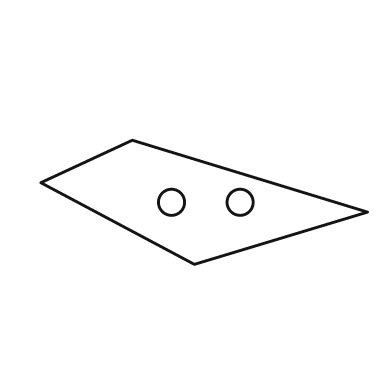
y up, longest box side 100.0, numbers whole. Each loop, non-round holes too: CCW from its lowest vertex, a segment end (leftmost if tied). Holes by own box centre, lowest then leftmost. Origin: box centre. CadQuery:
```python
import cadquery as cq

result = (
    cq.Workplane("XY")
    .moveTo(-3.0, -19.0)
    .lineTo(50.0, -3.0)
    .lineTo(-22.0, 19.0)
    .lineTo(-50.0, 6.0)
    .close()
    .moveTo(-10.0, 0.0)
    .circle(4.0)
    .moveTo(11.0, 0.0)
    .circle(4.0)
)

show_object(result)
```